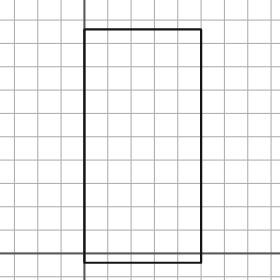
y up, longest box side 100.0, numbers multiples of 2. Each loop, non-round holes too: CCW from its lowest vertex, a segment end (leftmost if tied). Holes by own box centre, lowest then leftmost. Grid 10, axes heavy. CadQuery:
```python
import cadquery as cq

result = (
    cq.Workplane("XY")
    .moveTo(0.0, -4.0)
    .lineTo(50.0, -4.0)
    .lineTo(50.0, 96.0)
    .lineTo(0.0, 96.0)
    .close()
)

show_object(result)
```